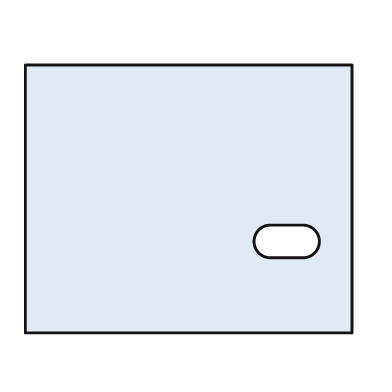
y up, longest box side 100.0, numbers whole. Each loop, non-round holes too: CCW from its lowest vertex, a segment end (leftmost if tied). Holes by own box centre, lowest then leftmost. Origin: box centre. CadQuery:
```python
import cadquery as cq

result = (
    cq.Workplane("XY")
    .moveTo(-50.0, -41.0)
    .lineTo(50.0, -41.0)
    .lineTo(50.0, 41.0)
    .lineTo(-50.0, 41.0)
    .close()
    .moveTo(25.0, -18.0)
    .lineTo(35.0, -18.0)
    .threePointArc((40.0, -13.0), (35.0, -8.0))
    .lineTo(25.0, -8.0)
    .threePointArc((20.0, -13.0), (25.0, -18.0))
    .close()
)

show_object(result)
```